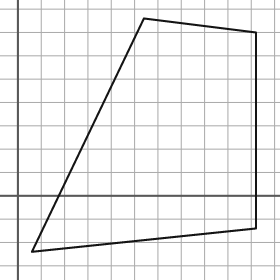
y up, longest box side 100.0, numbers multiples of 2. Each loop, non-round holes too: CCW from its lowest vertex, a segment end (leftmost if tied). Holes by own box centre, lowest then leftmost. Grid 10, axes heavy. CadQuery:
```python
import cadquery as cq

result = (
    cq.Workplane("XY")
    .moveTo(6.0, -24.0)
    .lineTo(102.0, -14.0)
    .lineTo(102.0, 70.0)
    .lineTo(54.0, 76.0)
    .close()
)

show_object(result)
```